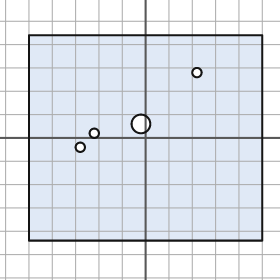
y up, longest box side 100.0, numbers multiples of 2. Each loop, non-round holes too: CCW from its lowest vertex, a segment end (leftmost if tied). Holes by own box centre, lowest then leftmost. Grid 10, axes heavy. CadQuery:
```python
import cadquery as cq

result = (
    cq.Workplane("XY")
    .moveTo(-50.0, -44.0)
    .lineTo(50.0, -44.0)
    .lineTo(50.0, 44.0)
    .lineTo(-50.0, 44.0)
    .close()
    .moveTo(-28.0, -4.0)
    .circle(2.0)
    .moveTo(-22.0, 2.0)
    .circle(2.0)
    .moveTo(-2.0, 6.0)
    .circle(4.0)
    .moveTo(22.0, 28.0)
    .circle(2.0)
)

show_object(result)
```